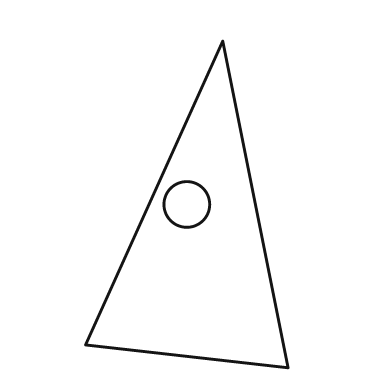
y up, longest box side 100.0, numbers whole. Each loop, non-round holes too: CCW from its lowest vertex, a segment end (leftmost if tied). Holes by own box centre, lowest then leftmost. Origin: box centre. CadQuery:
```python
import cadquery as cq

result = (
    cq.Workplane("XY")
    .moveTo(31.0, -50.0)
    .lineTo(11.0, 50.0)
    .lineTo(-31.0, -43.0)
    .close()
    .moveTo(0.0, 0.0)
    .circle(7.0)
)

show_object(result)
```